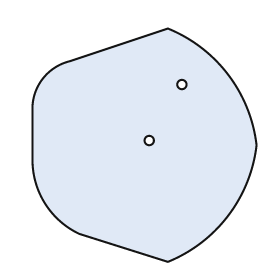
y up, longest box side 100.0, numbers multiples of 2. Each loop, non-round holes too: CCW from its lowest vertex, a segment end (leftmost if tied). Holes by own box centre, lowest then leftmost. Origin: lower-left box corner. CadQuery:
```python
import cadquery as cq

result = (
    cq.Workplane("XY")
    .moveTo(58.0, 0.0)
    .threePointArc((84.0, 20.0), (96.0, 50.0))
    .threePointArc((84.0, 80.0), (58.0, 100.0))
    .lineTo(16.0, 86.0)
    .threePointArc((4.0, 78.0), (0.0, 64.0))
    .lineTo(0.0, 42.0)
    .threePointArc((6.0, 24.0), (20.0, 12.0))
    .close()
    .moveTo(50.0, 52.0)
    .circle(2.0)
    .moveTo(64.0, 76.0)
    .circle(2.0)
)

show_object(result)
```